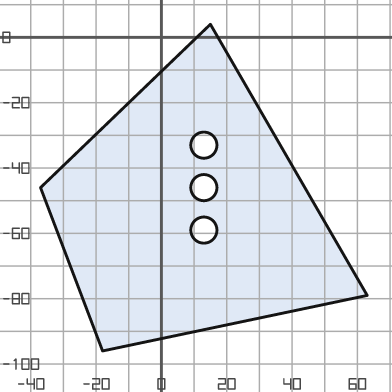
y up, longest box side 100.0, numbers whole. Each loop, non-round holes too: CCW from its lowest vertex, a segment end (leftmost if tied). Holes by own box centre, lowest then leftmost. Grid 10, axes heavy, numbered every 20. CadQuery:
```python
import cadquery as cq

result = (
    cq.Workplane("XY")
    .moveTo(-18.0, -96.0)
    .lineTo(63.0, -79.0)
    .lineTo(15.0, 4.0)
    .lineTo(-37.0, -46.0)
    .close()
    .moveTo(13.0, -59.0)
    .circle(4.0)
    .moveTo(13.0, -46.0)
    .circle(4.0)
    .moveTo(13.0, -33.0)
    .circle(4.0)
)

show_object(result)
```